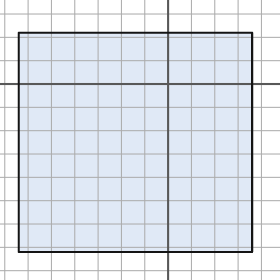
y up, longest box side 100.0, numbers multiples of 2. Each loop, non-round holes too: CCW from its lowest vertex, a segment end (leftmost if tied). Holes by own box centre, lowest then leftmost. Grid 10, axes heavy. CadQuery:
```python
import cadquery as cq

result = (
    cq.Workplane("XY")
    .moveTo(-64.0, -72.0)
    .lineTo(36.0, -72.0)
    .lineTo(36.0, 22.0)
    .lineTo(-64.0, 22.0)
    .close()
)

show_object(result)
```